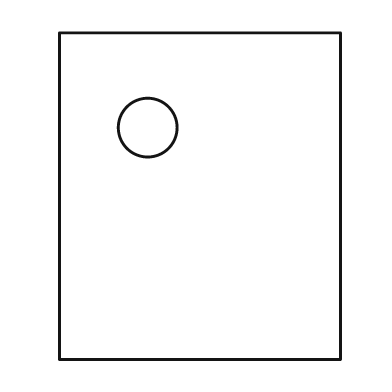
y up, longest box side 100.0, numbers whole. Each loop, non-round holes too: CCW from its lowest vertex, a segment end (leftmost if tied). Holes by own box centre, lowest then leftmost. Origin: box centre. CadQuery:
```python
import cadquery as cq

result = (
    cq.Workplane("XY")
    .moveTo(-43.0, -50.0)
    .lineTo(43.0, -50.0)
    .lineTo(43.0, 50.0)
    .lineTo(-43.0, 50.0)
    .close()
    .moveTo(-16.0, 21.0)
    .circle(9.0)
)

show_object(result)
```